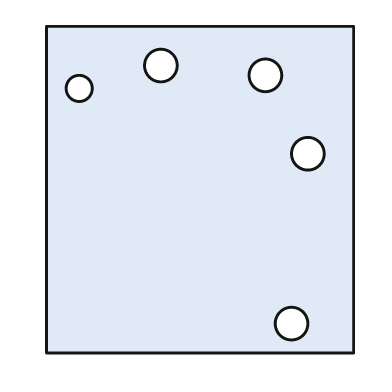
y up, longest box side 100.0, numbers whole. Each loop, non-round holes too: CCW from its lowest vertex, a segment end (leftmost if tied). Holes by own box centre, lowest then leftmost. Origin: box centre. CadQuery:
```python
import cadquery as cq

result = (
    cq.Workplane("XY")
    .moveTo(-47.0, -50.0)
    .lineTo(47.0, -50.0)
    .lineTo(47.0, 50.0)
    .lineTo(-47.0, 50.0)
    .close()
    .moveTo(28.0, -41.0)
    .circle(5.0)
    .moveTo(33.0, 11.0)
    .circle(5.0)
    .moveTo(-37.0, 31.0)
    .circle(4.0)
    .moveTo(20.0, 35.0)
    .circle(5.0)
    .moveTo(-12.0, 38.0)
    .circle(5.0)
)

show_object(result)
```